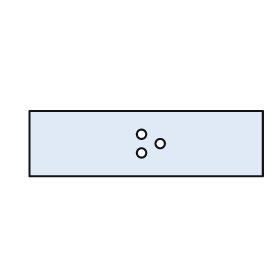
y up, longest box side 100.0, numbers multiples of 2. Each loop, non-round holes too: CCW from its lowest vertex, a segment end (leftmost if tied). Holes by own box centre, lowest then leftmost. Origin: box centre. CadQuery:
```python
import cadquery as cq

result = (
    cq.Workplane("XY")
    .moveTo(-50.0, -14.0)
    .lineTo(50.0, -14.0)
    .lineTo(50.0, 14.0)
    .lineTo(-50.0, 14.0)
    .close()
    .moveTo(-2.0, -4.0)
    .circle(2.0)
    .moveTo(6.0, 0.0)
    .circle(2.0)
    .moveTo(-2.0, 4.0)
    .circle(2.0)
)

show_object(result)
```